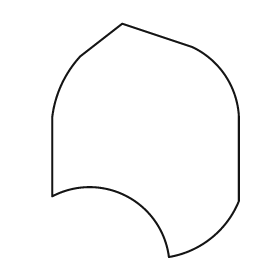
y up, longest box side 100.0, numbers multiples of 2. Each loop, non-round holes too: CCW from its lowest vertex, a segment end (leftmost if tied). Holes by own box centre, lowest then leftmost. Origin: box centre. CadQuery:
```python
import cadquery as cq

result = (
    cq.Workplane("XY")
    .moveTo(10.0, -50.0)
    .threePointArc((28.0, -42.0), (40.0, -26.0))
    .lineTo(40.0, 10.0)
    .threePointArc((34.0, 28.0), (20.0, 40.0))
    .lineTo(-10.0, 50.0)
    .lineTo(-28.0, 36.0)
    .threePointArc((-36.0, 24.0), (-40.0, 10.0))
    .lineTo(-40.0, -24.0)
    .threePointArc((-8.0, -24.0), (10.0, -50.0))
    .close()
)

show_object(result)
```